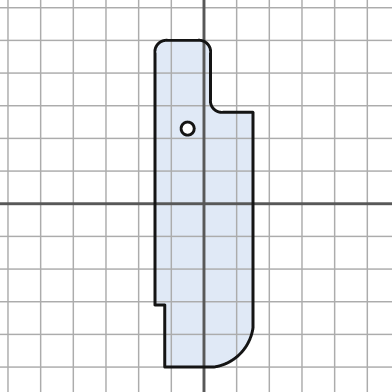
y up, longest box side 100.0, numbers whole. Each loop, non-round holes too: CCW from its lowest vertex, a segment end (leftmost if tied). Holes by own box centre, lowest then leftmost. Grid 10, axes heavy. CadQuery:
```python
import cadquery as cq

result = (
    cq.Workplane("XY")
    .moveTo(-12.0, -50.0)
    .lineTo(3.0, -50.0)
    .threePointArc((11.0, -46.0), (15.0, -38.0))
    .lineTo(15.0, 28.0)
    .lineTo(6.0, 28.0)
    .threePointArc((3.0, 29.0), (2.0, 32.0))
    .lineTo(2.0, 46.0)
    .threePointArc((1.0, 49.0), (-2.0, 50.0))
    .lineTo(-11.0, 50.0)
    .threePointArc((-14.0, 49.0), (-15.0, 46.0))
    .lineTo(-15.0, -31.0)
    .lineTo(-12.0, -31.0)
    .close()
    .moveTo(-5.0, 23.0)
    .circle(2.0)
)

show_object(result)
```